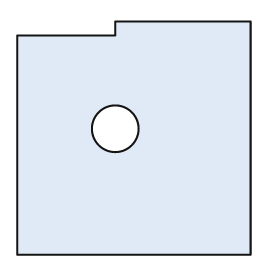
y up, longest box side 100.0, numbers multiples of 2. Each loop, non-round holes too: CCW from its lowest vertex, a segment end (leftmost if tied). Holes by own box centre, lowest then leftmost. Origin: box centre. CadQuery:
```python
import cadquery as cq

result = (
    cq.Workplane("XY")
    .moveTo(-50.0, -50.0)
    .lineTo(50.0, -50.0)
    .lineTo(50.0, 50.0)
    .lineTo(-8.0, 50.0)
    .lineTo(-8.0, 44.0)
    .lineTo(-50.0, 44.0)
    .close()
    .moveTo(-8.0, 4.0)
    .circle(10.0)
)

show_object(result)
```